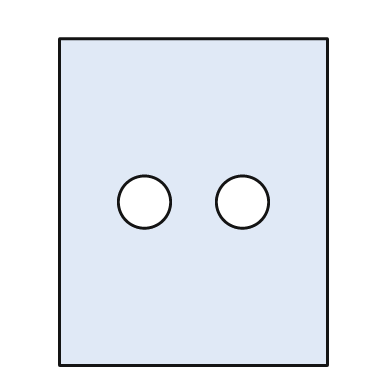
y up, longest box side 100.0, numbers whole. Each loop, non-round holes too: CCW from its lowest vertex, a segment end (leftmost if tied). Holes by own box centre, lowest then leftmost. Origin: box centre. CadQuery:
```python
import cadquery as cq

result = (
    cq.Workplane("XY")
    .moveTo(-41.0, -50.0)
    .lineTo(41.0, -50.0)
    .lineTo(41.0, 50.0)
    .lineTo(-41.0, 50.0)
    .close()
    .moveTo(-15.0, 0.0)
    .circle(8.0)
    .moveTo(15.0, 0.0)
    .circle(8.0)
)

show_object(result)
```